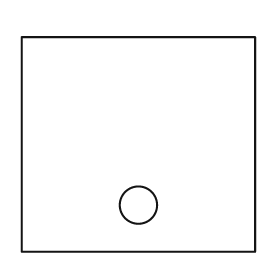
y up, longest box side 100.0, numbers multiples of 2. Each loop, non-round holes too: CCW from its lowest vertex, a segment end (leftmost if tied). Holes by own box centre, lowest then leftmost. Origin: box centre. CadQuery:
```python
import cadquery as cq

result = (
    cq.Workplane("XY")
    .moveTo(-50.0, -46.0)
    .lineTo(50.0, -46.0)
    .lineTo(50.0, 46.0)
    .lineTo(-50.0, 46.0)
    .close()
    .moveTo(0.0, -26.0)
    .circle(8.0)
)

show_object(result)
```